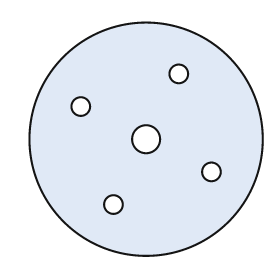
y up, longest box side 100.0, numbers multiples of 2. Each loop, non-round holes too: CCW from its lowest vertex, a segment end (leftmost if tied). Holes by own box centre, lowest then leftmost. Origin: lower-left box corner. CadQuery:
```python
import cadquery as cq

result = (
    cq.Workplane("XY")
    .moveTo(50.0, 50.0)
    .circle(50.0)
    .moveTo(36.0, 22.0)
    .circle(4.0)
    .moveTo(78.0, 36.0)
    .circle(4.0)
    .moveTo(50.0, 50.0)
    .circle(6.0)
    .moveTo(22.0, 64.0)
    .circle(4.0)
    .moveTo(64.0, 78.0)
    .circle(4.0)
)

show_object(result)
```